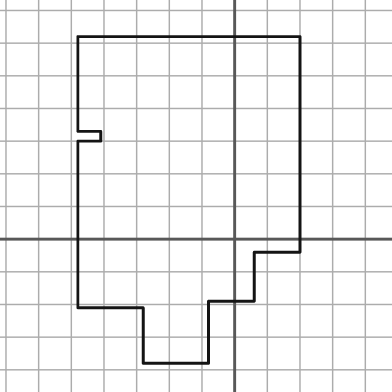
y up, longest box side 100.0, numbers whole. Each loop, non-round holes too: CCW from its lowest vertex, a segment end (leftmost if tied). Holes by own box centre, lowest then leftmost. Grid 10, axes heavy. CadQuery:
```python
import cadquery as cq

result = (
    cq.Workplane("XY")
    .moveTo(-28.0, -38.0)
    .lineTo(-8.0, -38.0)
    .lineTo(-8.0, -19.0)
    .lineTo(6.0, -19.0)
    .lineTo(6.0, -4.0)
    .lineTo(20.0, -4.0)
    .lineTo(20.0, 62.0)
    .lineTo(-48.0, 62.0)
    .lineTo(-48.0, 33.0)
    .lineTo(-41.0, 33.0)
    .lineTo(-41.0, 30.0)
    .lineTo(-48.0, 30.0)
    .lineTo(-48.0, -21.0)
    .lineTo(-28.0, -21.0)
    .close()
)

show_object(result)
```